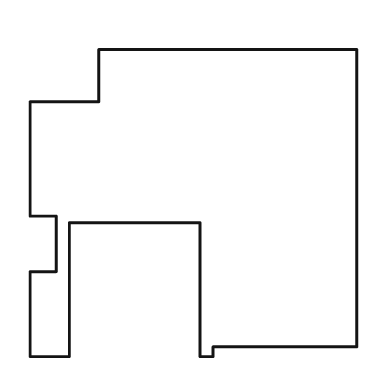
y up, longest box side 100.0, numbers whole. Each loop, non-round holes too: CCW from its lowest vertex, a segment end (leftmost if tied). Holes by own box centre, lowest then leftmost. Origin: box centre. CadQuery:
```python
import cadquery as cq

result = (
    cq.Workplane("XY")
    .moveTo(-50.0, -47.0)
    .lineTo(-38.0, -47.0)
    .lineTo(-38.0, -6.0)
    .lineTo(2.0, -6.0)
    .lineTo(2.0, -47.0)
    .lineTo(6.0, -47.0)
    .lineTo(6.0, -44.0)
    .lineTo(50.0, -44.0)
    .lineTo(50.0, 47.0)
    .lineTo(-29.0, 47.0)
    .lineTo(-29.0, 31.0)
    .lineTo(-50.0, 31.0)
    .lineTo(-50.0, -4.0)
    .lineTo(-42.0, -4.0)
    .lineTo(-42.0, -21.0)
    .lineTo(-50.0, -21.0)
    .close()
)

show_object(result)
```